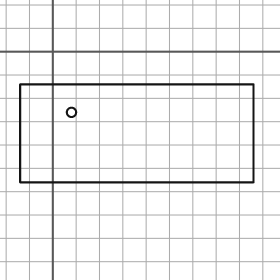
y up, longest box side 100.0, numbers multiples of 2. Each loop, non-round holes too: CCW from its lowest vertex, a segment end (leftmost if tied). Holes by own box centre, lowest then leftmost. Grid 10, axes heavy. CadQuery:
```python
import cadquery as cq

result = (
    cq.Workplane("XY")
    .moveTo(-14.0, -56.0)
    .lineTo(86.0, -56.0)
    .lineTo(86.0, -14.0)
    .lineTo(-14.0, -14.0)
    .close()
    .moveTo(8.0, -26.0)
    .circle(2.0)
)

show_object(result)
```